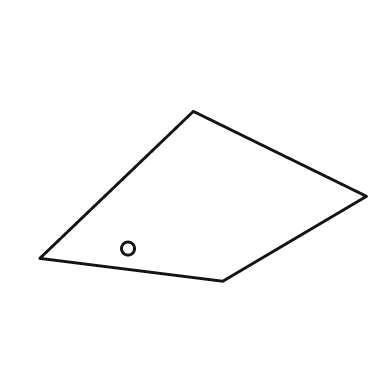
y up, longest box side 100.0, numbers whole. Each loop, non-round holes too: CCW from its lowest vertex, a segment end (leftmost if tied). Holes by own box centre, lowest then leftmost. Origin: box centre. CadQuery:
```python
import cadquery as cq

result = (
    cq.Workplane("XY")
    .moveTo(6.0, -26.0)
    .lineTo(50.0, 0.0)
    .lineTo(-3.0, 26.0)
    .lineTo(-50.0, -19.0)
    .close()
    .moveTo(-23.0, -16.0)
    .circle(2.0)
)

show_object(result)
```